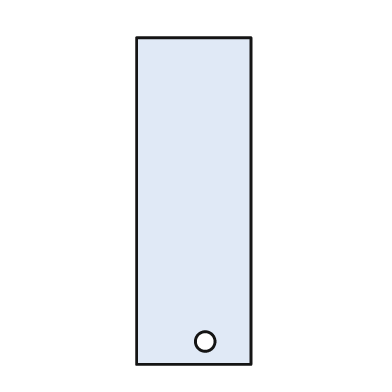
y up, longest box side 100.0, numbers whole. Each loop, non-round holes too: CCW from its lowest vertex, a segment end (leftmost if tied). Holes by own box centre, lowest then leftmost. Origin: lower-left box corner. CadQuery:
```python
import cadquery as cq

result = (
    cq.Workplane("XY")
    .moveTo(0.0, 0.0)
    .lineTo(35.0, 0.0)
    .lineTo(35.0, 100.0)
    .lineTo(0.0, 100.0)
    .close()
    .moveTo(21.0, 7.0)
    .circle(3.0)
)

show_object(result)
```